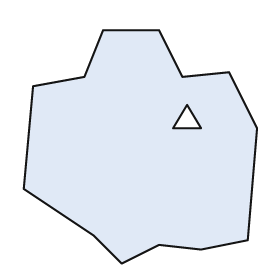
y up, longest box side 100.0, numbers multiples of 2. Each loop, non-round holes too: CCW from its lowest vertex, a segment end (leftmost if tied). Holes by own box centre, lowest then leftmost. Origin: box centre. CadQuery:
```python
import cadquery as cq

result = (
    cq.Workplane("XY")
    .moveTo(-8.0, -50.0)
    .lineTo(8.0, -42.0)
    .lineTo(26.0, -44.0)
    .lineTo(46.0, -40.0)
    .lineTo(50.0, 8.0)
    .lineTo(38.0, 32.0)
    .lineTo(18.0, 30.0)
    .lineTo(8.0, 50.0)
    .lineTo(-16.0, 50.0)
    .lineTo(-24.0, 30.0)
    .lineTo(-46.0, 26.0)
    .lineTo(-50.0, -18.0)
    .lineTo(-20.0, -38.0)
    .close()
    .moveTo(14.0, 8.0)
    .lineTo(26.0, 8.0)
    .lineTo(20.0, 18.0)
    .close()
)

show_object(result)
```